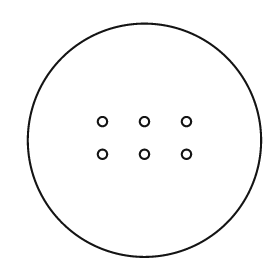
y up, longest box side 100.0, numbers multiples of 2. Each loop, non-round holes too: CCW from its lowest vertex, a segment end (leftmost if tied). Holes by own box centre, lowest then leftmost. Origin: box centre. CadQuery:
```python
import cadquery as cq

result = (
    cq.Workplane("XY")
    .moveTo(0.0, 0.0)
    .circle(50.0)
    .moveTo(-18.0, -6.0)
    .circle(2.0)
    .moveTo(0.0, -6.0)
    .circle(2.0)
    .moveTo(18.0, -6.0)
    .circle(2.0)
    .moveTo(-18.0, 8.0)
    .circle(2.0)
    .moveTo(0.0, 8.0)
    .circle(2.0)
    .moveTo(18.0, 8.0)
    .circle(2.0)
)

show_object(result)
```